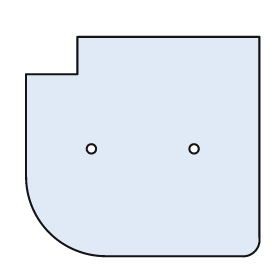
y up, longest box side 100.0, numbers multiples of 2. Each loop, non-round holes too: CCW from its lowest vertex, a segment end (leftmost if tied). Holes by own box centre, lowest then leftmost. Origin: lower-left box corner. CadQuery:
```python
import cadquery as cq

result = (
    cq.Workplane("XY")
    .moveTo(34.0, 0.0)
    .lineTo(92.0, 0.0)
    .threePointArc((98.0, 2.0), (100.0, 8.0))
    .lineTo(100.0, 94.0)
    .lineTo(22.0, 94.0)
    .lineTo(22.0, 78.0)
    .lineTo(0.0, 78.0)
    .lineTo(0.0, 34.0)
    .threePointArc((10.0, 10.0), (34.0, 0.0))
    .close()
    .moveTo(28.0, 46.0)
    .circle(2.0)
    .moveTo(72.0, 46.0)
    .circle(2.0)
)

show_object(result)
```